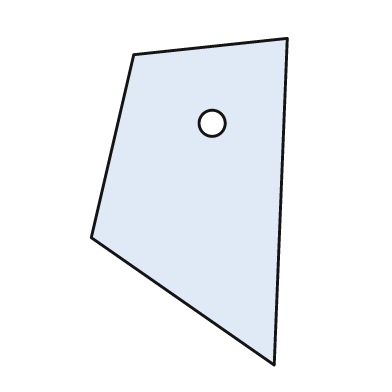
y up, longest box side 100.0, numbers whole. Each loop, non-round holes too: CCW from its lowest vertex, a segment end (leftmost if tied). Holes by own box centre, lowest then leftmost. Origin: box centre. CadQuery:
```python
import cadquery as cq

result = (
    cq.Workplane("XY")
    .moveTo(26.0, -50.0)
    .lineTo(30.0, 50.0)
    .lineTo(-17.0, 45.0)
    .lineTo(-30.0, -11.0)
    .close()
    .moveTo(7.0, 24.0)
    .circle(4.0)
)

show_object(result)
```